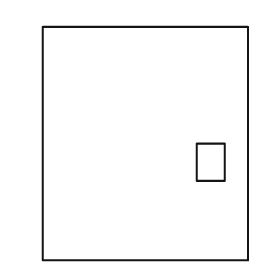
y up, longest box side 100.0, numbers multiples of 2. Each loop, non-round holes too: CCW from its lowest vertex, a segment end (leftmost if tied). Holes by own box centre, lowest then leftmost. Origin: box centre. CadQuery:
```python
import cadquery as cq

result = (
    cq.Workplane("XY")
    .moveTo(-44.0, -50.0)
    .lineTo(44.0, -50.0)
    .lineTo(44.0, 50.0)
    .lineTo(-44.0, 50.0)
    .close()
    .moveTo(22.0, -16.0)
    .lineTo(34.0, -16.0)
    .lineTo(34.0, 0.0)
    .lineTo(22.0, 0.0)
    .close()
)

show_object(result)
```